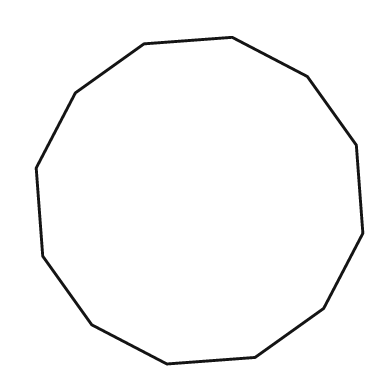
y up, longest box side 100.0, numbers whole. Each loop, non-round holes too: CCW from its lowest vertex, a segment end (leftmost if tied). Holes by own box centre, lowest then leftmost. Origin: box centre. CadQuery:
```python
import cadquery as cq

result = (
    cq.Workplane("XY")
    .moveTo(-10.0, -50.0)
    .lineTo(17.0, -48.0)
    .lineTo(38.0, -33.0)
    .lineTo(50.0, -10.0)
    .lineTo(48.0, 17.0)
    .lineTo(33.0, 38.0)
    .lineTo(10.0, 50.0)
    .lineTo(-17.0, 48.0)
    .lineTo(-38.0, 33.0)
    .lineTo(-50.0, 10.0)
    .lineTo(-48.0, -17.0)
    .lineTo(-33.0, -38.0)
    .close()
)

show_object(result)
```